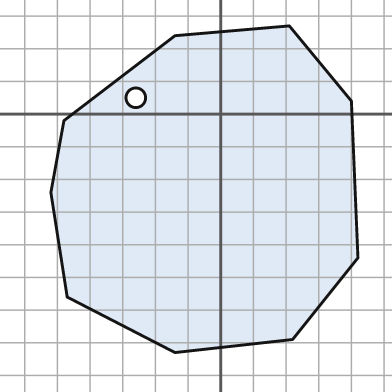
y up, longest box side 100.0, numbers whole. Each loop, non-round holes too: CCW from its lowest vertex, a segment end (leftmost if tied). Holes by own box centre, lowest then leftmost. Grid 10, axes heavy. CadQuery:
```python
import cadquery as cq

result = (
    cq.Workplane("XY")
    .moveTo(-14.0, -73.0)
    .lineTo(22.0, -69.0)
    .lineTo(42.0, -44.0)
    .lineTo(40.0, 4.0)
    .lineTo(21.0, 27.0)
    .lineTo(-14.0, 24.0)
    .lineTo(-48.0, -2.0)
    .lineTo(-52.0, -24.0)
    .lineTo(-47.0, -56.0)
    .close()
    .moveTo(-26.0, 5.0)
    .circle(3.0)
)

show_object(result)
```